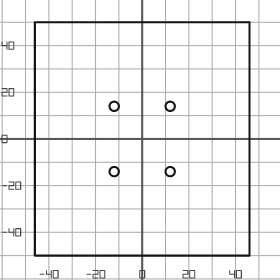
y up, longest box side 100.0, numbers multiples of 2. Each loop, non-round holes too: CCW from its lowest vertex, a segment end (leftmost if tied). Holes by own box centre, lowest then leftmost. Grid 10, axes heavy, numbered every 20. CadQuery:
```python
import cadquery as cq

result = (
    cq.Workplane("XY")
    .moveTo(-46.0, -50.0)
    .lineTo(46.0, -50.0)
    .lineTo(46.0, 50.0)
    .lineTo(-46.0, 50.0)
    .close()
    .moveTo(-12.0, -14.0)
    .circle(2.0)
    .moveTo(12.0, -14.0)
    .circle(2.0)
    .moveTo(-12.0, 14.0)
    .circle(2.0)
    .moveTo(12.0, 14.0)
    .circle(2.0)
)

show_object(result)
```